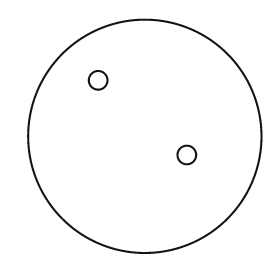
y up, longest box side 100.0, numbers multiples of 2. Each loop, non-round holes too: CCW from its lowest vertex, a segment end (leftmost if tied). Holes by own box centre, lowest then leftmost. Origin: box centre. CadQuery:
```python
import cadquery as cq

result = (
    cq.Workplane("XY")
    .moveTo(0.0, 0.0)
    .circle(50.0)
    .moveTo(18.0, -8.0)
    .circle(4.0)
    .moveTo(-20.0, 24.0)
    .circle(4.0)
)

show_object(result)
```